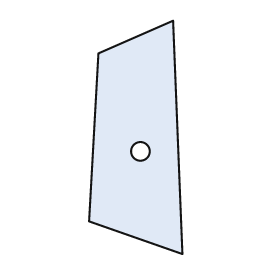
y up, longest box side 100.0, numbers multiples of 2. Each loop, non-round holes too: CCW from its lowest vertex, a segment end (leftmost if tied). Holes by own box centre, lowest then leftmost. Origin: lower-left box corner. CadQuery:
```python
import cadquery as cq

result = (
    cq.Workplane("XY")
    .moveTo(40.0, 0.0)
    .lineTo(36.0, 100.0)
    .lineTo(4.0, 86.0)
    .lineTo(0.0, 14.0)
    .close()
    .moveTo(22.0, 44.0)
    .circle(4.0)
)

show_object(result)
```